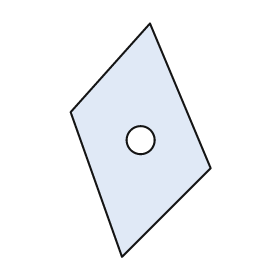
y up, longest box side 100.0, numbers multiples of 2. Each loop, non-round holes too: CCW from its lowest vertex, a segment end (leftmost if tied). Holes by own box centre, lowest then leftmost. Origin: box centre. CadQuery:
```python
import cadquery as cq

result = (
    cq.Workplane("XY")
    .moveTo(-8.0, -50.0)
    .lineTo(30.0, -12.0)
    .lineTo(4.0, 50.0)
    .lineTo(-30.0, 12.0)
    .close()
    .moveTo(0.0, 0.0)
    .circle(6.0)
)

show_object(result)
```